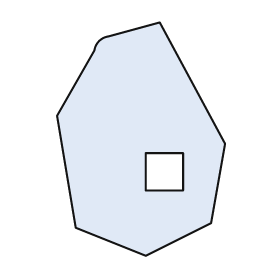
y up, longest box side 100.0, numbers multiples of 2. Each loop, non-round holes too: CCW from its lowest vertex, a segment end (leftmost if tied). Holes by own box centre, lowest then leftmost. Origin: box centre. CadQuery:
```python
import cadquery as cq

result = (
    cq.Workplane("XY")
    .moveTo(2.0, -50.0)
    .lineTo(30.0, -36.0)
    .lineTo(36.0, -2.0)
    .lineTo(8.0, 50.0)
    .lineTo(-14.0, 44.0)
    .threePointArc((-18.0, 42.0), (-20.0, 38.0))
    .lineTo(-36.0, 10.0)
    .lineTo(-28.0, -38.0)
    .close()
    .moveTo(2.0, -22.0)
    .lineTo(18.0, -22.0)
    .lineTo(18.0, -6.0)
    .lineTo(2.0, -6.0)
    .close()
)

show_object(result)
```